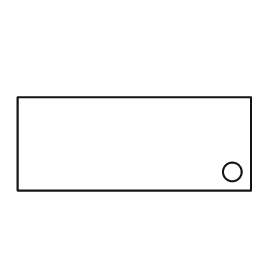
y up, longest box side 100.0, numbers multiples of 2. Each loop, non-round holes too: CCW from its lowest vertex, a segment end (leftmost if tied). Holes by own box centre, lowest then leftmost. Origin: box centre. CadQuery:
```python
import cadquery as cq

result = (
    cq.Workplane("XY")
    .moveTo(-50.0, -20.0)
    .lineTo(50.0, -20.0)
    .lineTo(50.0, 20.0)
    .lineTo(-50.0, 20.0)
    .close()
    .moveTo(42.0, -12.0)
    .circle(4.0)
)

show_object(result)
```